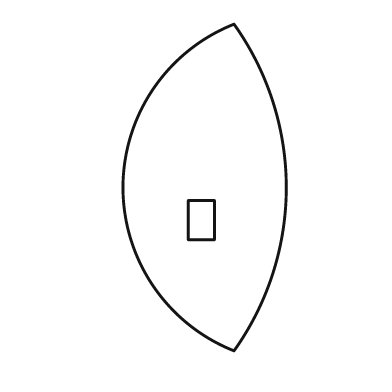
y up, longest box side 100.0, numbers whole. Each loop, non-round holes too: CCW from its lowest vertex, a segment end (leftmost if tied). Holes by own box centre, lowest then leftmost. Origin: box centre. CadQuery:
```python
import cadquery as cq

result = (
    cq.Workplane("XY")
    .moveTo(9.0, -50.0)
    .threePointArc((25.0, 0.0), (9.0, 50.0))
    .threePointArc((-25.0, 0.0), (9.0, -50.0))
    .close()
    .moveTo(-5.0, -16.0)
    .lineTo(3.0, -16.0)
    .lineTo(3.0, -4.0)
    .lineTo(-5.0, -4.0)
    .close()
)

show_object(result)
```